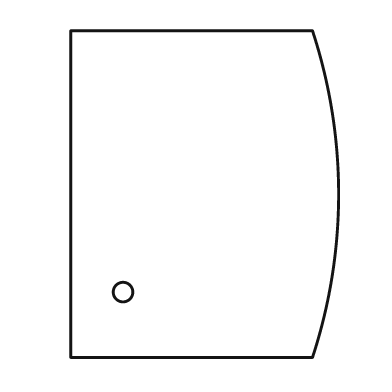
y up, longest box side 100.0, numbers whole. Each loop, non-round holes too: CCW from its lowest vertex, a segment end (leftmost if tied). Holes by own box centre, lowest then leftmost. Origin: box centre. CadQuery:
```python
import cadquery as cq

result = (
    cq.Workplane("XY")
    .moveTo(-41.0, -50.0)
    .lineTo(33.0, -50.0)
    .threePointArc((41.0, 0.0), (33.0, 50.0))
    .lineTo(-41.0, 50.0)
    .close()
    .moveTo(-25.0, -30.0)
    .circle(3.0)
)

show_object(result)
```